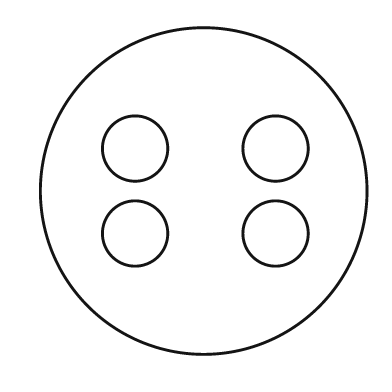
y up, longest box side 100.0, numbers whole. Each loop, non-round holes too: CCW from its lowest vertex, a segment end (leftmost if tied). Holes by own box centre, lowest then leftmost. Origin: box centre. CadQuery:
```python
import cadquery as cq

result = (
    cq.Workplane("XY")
    .moveTo(0.0, 0.0)
    .circle(50.0)
    .moveTo(-21.0, -13.0)
    .circle(10.0)
    .moveTo(22.0, -13.0)
    .circle(10.0)
    .moveTo(-21.0, 13.0)
    .circle(10.0)
    .moveTo(22.0, 13.0)
    .circle(10.0)
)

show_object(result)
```